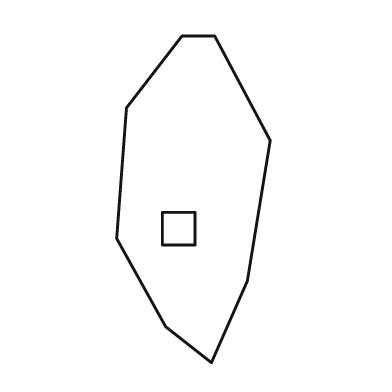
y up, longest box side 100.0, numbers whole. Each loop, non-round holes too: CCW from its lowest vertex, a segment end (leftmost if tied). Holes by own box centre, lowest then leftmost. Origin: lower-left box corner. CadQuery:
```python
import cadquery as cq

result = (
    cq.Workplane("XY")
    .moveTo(29.0, 0.0)
    .lineTo(40.0, 25.0)
    .lineTo(47.0, 68.0)
    .lineTo(30.0, 100.0)
    .lineTo(20.0, 100.0)
    .lineTo(3.0, 78.0)
    .lineTo(0.0, 38.0)
    .lineTo(15.0, 11.0)
    .close()
    .moveTo(14.0, 36.0)
    .lineTo(24.0, 36.0)
    .lineTo(24.0, 46.0)
    .lineTo(14.0, 46.0)
    .close()
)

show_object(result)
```